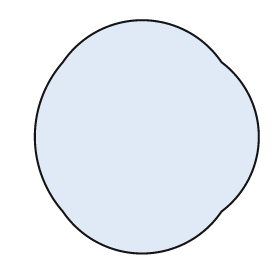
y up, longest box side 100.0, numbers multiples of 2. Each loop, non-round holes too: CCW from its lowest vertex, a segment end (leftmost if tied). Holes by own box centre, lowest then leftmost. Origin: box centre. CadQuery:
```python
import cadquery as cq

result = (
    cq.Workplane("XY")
    .moveTo(-36.0, -32.0)
    .threePointArc((-2.0, -50.0), (32.0, -32.0))
    .threePointArc((48.0, 0.0), (32.0, 32.0))
    .threePointArc((-2.0, 50.0), (-36.0, 32.0))
    .threePointArc((-48.0, 0.0), (-36.0, -32.0))
    .close()
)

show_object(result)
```